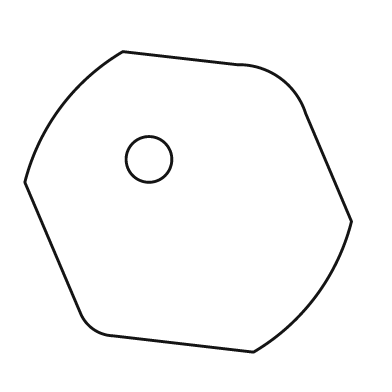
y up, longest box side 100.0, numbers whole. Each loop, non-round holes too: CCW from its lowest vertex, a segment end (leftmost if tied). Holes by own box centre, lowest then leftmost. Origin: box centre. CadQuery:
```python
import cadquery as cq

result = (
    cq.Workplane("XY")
    .moveTo(20.0, -46.0)
    .threePointArc((39.0, -29.0), (50.0, -6.0))
    .lineTo(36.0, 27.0)
    .threePointArc((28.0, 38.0), (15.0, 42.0))
    .lineTo(-20.0, 46.0)
    .threePointArc((-39.0, 29.0), (-50.0, 6.0))
    .lineTo(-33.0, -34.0)
    .threePointArc((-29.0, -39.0), (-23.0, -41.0))
    .close()
    .moveTo(-12.0, 13.0)
    .circle(7.0)
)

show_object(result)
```